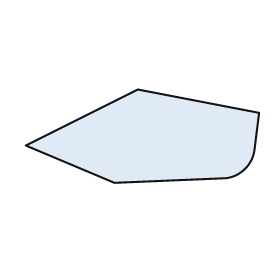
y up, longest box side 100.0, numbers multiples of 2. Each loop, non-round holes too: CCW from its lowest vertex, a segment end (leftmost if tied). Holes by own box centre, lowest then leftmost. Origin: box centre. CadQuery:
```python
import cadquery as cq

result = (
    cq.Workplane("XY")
    .moveTo(-12.0, -20.0)
    .lineTo(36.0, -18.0)
    .threePointArc((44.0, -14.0), (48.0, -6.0))
    .lineTo(50.0, 10.0)
    .lineTo(-2.0, 20.0)
    .lineTo(-50.0, -4.0)
    .close()
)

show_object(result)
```